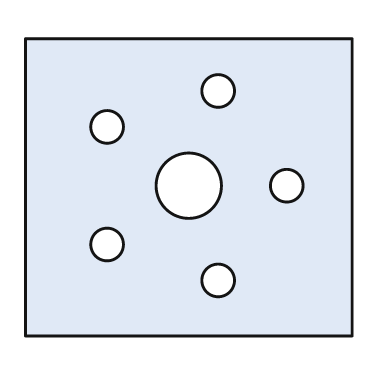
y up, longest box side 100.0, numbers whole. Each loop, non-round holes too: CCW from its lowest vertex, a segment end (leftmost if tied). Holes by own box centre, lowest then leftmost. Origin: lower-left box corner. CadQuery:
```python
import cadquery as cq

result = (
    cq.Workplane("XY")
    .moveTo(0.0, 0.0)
    .lineTo(100.0, 0.0)
    .lineTo(100.0, 91.0)
    .lineTo(0.0, 91.0)
    .close()
    .moveTo(59.0, 17.0)
    .circle(5.0)
    .moveTo(25.0, 28.0)
    .circle(5.0)
    .moveTo(50.0, 46.0)
    .circle(10.0)
    .moveTo(80.0, 46.0)
    .circle(5.0)
    .moveTo(25.0, 64.0)
    .circle(5.0)
    .moveTo(59.0, 75.0)
    .circle(5.0)
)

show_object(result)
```